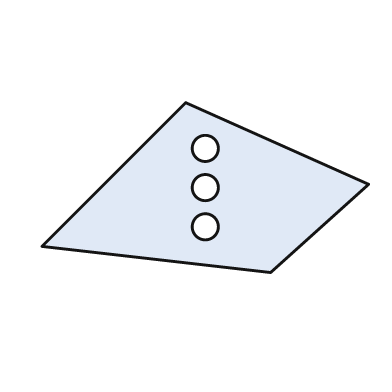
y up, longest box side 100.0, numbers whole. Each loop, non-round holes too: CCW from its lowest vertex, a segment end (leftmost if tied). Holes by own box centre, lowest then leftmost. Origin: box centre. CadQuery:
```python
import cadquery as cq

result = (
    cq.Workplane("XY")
    .moveTo(20.0, -26.0)
    .lineTo(50.0, 1.0)
    .lineTo(-6.0, 26.0)
    .lineTo(-50.0, -18.0)
    .close()
    .moveTo(0.0, -12.0)
    .circle(4.0)
    .moveTo(0.0, 0.0)
    .circle(4.0)
    .moveTo(0.0, 12.0)
    .circle(4.0)
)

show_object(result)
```